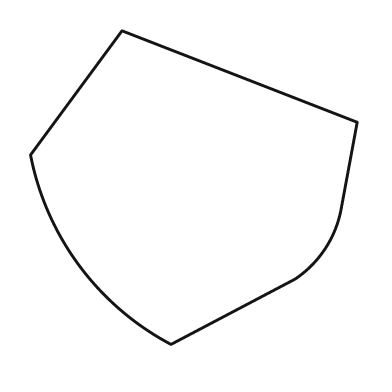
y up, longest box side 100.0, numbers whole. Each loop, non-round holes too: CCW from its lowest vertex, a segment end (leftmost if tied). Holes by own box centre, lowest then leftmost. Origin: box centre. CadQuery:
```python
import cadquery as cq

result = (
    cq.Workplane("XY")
    .moveTo(-7.0, -48.0)
    .lineTo(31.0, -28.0)
    .threePointArc((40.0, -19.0), (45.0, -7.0))
    .lineTo(50.0, 20.0)
    .lineTo(-22.0, 48.0)
    .lineTo(-50.0, 10.0)
    .threePointArc((-35.0, -24.0), (-7.0, -48.0))
    .close()
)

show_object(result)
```